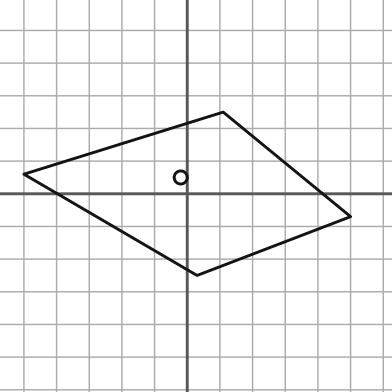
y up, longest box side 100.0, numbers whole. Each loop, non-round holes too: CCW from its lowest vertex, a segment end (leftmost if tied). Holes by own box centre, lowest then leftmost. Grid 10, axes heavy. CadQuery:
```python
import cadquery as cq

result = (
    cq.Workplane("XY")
    .moveTo(3.0, -25.0)
    .lineTo(50.0, -7.0)
    .lineTo(11.0, 25.0)
    .lineTo(-50.0, 6.0)
    .close()
    .moveTo(-2.0, 5.0)
    .circle(2.0)
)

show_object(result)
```